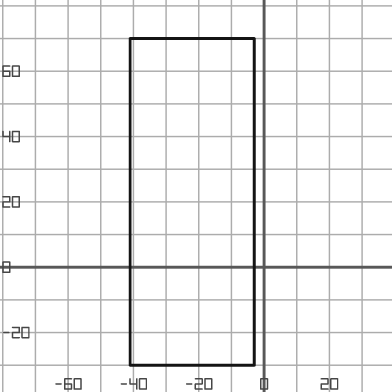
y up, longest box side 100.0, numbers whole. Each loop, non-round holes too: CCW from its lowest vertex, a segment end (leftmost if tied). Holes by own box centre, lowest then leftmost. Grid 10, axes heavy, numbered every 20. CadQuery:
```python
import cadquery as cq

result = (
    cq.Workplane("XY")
    .moveTo(-41.0, -30.0)
    .lineTo(-3.0, -30.0)
    .lineTo(-3.0, 70.0)
    .lineTo(-41.0, 70.0)
    .close()
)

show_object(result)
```